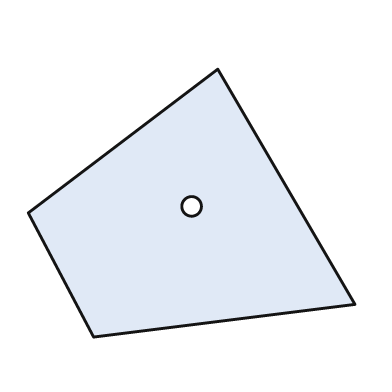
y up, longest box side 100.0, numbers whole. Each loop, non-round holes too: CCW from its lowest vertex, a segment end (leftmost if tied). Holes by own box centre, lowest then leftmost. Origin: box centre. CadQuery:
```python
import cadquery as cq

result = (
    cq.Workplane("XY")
    .moveTo(-30.0, -41.0)
    .lineTo(50.0, -31.0)
    .lineTo(8.0, 41.0)
    .lineTo(-50.0, -3.0)
    .close()
    .moveTo(0.0, -1.0)
    .circle(3.0)
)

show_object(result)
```